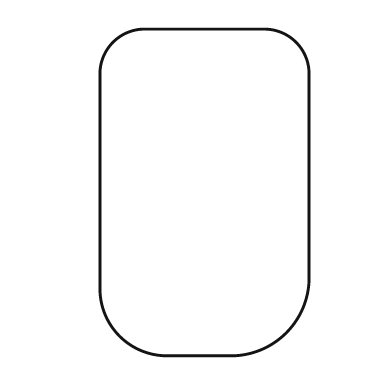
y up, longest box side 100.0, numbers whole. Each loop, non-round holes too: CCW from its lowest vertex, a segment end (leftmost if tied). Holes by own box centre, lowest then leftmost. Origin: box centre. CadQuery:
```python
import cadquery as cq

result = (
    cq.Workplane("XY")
    .moveTo(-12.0, -50.0)
    .lineTo(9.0, -50.0)
    .threePointArc((25.0, -43.0), (32.0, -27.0))
    .lineTo(32.0, 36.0)
    .threePointArc((28.0, 46.0), (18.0, 50.0))
    .lineTo(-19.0, 50.0)
    .threePointArc((-28.0, 46.0), (-32.0, 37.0))
    .lineTo(-32.0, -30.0)
    .threePointArc((-26.0, -44.0), (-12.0, -50.0))
    .close()
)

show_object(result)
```